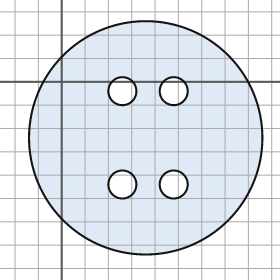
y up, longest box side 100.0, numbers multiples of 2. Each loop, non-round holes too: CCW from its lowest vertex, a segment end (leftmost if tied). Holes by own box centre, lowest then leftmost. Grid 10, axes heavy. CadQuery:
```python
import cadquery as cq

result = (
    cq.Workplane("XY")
    .moveTo(36.0, -24.0)
    .circle(50.0)
    .moveTo(26.0, -44.0)
    .circle(6.0)
    .moveTo(48.0, -44.0)
    .circle(6.0)
    .moveTo(26.0, -4.0)
    .circle(6.0)
    .moveTo(48.0, -4.0)
    .circle(6.0)
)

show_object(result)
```